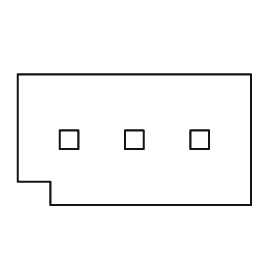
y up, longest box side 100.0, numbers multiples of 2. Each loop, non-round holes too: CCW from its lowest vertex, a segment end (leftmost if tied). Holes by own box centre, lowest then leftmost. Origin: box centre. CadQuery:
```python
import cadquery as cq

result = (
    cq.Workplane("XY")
    .moveTo(-36.0, -28.0)
    .lineTo(50.0, -28.0)
    .lineTo(50.0, 28.0)
    .lineTo(-50.0, 28.0)
    .lineTo(-50.0, -18.0)
    .lineTo(-36.0, -18.0)
    .close()
    .moveTo(-32.0, -4.0)
    .lineTo(-24.0, -4.0)
    .lineTo(-24.0, 4.0)
    .lineTo(-32.0, 4.0)
    .close()
    .moveTo(-4.0, -4.0)
    .lineTo(4.0, -4.0)
    .lineTo(4.0, 4.0)
    .lineTo(-4.0, 4.0)
    .close()
    .moveTo(24.0, -4.0)
    .lineTo(32.0, -4.0)
    .lineTo(32.0, 4.0)
    .lineTo(24.0, 4.0)
    .close()
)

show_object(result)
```